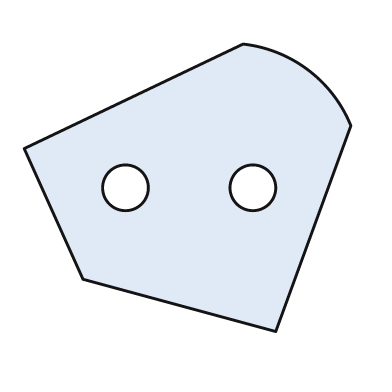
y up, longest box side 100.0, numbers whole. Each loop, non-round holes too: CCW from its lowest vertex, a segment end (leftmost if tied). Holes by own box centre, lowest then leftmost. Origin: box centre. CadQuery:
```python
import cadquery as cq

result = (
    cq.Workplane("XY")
    .moveTo(27.0, -44.0)
    .lineTo(50.0, 19.0)
    .threePointArc((37.0, 36.0), (17.0, 44.0))
    .lineTo(-50.0, 12.0)
    .lineTo(-32.0, -28.0)
    .close()
    .moveTo(-19.0, 0.0)
    .circle(7.0)
    .moveTo(20.0, 0.0)
    .circle(7.0)
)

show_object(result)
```